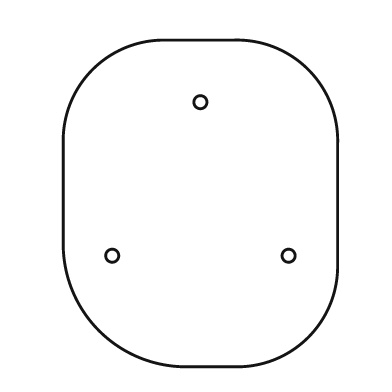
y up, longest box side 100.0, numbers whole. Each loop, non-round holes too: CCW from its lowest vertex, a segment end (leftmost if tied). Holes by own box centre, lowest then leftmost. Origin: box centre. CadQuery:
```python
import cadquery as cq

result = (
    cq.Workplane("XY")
    .moveTo(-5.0, -50.0)
    .lineTo(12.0, -50.0)
    .threePointArc((33.0, -41.0), (42.0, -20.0))
    .lineTo(42.0, 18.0)
    .threePointArc((33.0, 41.0), (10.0, 50.0))
    .lineTo(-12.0, 50.0)
    .threePointArc((-33.0, 41.0), (-42.0, 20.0))
    .lineTo(-42.0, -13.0)
    .threePointArc((-31.0, -39.0), (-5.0, -50.0))
    .close()
    .moveTo(-27.0, -16.0)
    .circle(2.0)
    .moveTo(27.0, -16.0)
    .circle(2.0)
    .moveTo(0.0, 31.0)
    .circle(2.0)
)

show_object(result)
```